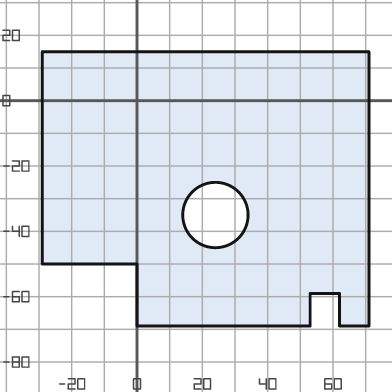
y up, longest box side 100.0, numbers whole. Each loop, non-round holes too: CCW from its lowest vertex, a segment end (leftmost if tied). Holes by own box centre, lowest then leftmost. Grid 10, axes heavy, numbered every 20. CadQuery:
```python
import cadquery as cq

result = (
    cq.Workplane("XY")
    .moveTo(0.0, -69.0)
    .lineTo(53.0, -69.0)
    .lineTo(53.0, -59.0)
    .lineTo(62.0, -59.0)
    .lineTo(62.0, -69.0)
    .lineTo(71.0, -69.0)
    .lineTo(71.0, 15.0)
    .lineTo(-29.0, 15.0)
    .lineTo(-29.0, -50.0)
    .lineTo(0.0, -50.0)
    .close()
    .moveTo(24.0, -35.0)
    .circle(10.0)
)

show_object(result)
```